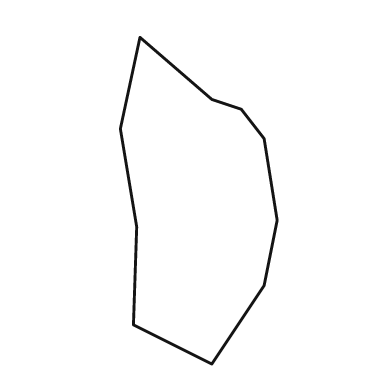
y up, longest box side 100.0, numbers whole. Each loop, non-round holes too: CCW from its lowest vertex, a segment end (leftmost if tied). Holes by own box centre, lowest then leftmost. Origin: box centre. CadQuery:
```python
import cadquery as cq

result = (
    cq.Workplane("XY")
    .moveTo(4.0, -50.0)
    .lineTo(20.0, -26.0)
    .lineTo(24.0, -6.0)
    .lineTo(20.0, 19.0)
    .lineTo(13.0, 28.0)
    .lineTo(4.0, 31.0)
    .lineTo(-18.0, 50.0)
    .lineTo(-24.0, 22.0)
    .lineTo(-19.0, -8.0)
    .lineTo(-20.0, -38.0)
    .close()
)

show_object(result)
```